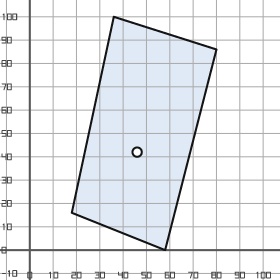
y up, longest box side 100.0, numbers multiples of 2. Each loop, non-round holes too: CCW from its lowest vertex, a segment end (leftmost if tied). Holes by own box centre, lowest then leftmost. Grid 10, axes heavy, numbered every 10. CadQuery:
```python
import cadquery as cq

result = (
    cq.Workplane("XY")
    .moveTo(58.0, 0.0)
    .lineTo(80.0, 86.0)
    .lineTo(36.0, 100.0)
    .lineTo(18.0, 16.0)
    .close()
    .moveTo(46.0, 42.0)
    .circle(2.0)
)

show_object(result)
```